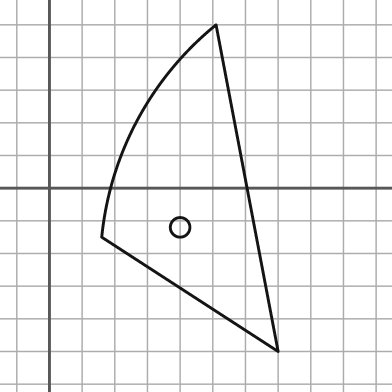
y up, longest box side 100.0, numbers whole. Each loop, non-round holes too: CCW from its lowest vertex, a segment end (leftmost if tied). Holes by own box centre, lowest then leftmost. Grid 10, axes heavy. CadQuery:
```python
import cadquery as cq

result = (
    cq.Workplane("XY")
    .moveTo(70.0, -50.0)
    .lineTo(51.0, 50.0)
    .threePointArc((27.0, 21.0), (16.0, -15.0))
    .close()
    .moveTo(40.0, -12.0)
    .circle(3.0)
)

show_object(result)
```